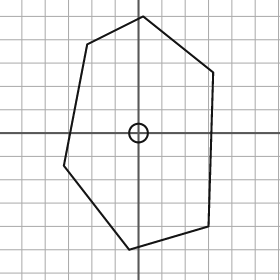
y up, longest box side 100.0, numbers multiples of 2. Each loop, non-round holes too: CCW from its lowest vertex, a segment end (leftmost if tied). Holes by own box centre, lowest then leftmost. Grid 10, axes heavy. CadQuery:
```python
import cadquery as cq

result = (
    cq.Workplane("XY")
    .moveTo(-4.0, -50.0)
    .lineTo(30.0, -40.0)
    .lineTo(32.0, 26.0)
    .lineTo(2.0, 50.0)
    .lineTo(-22.0, 38.0)
    .lineTo(-32.0, -14.0)
    .close()
    .moveTo(0.0, 0.0)
    .circle(4.0)
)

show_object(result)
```